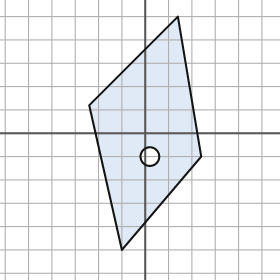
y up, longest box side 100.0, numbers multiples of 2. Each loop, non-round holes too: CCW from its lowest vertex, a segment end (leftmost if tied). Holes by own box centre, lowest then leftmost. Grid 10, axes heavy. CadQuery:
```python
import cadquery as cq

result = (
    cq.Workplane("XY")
    .moveTo(-10.0, -50.0)
    .lineTo(24.0, -10.0)
    .lineTo(14.0, 50.0)
    .lineTo(-24.0, 12.0)
    .close()
    .moveTo(2.0, -10.0)
    .circle(4.0)
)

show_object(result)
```